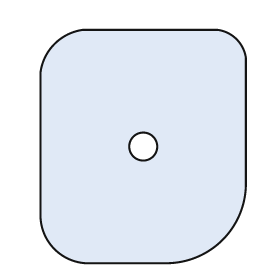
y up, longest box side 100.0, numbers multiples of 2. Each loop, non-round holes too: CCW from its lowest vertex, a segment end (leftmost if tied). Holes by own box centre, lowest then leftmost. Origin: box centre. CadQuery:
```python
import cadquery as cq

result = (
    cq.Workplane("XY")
    .moveTo(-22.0, -50.0)
    .lineTo(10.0, -50.0)
    .threePointArc((34.0, -40.0), (44.0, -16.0))
    .lineTo(44.0, 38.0)
    .threePointArc((40.0, 46.0), (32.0, 50.0))
    .lineTo(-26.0, 50.0)
    .threePointArc((-38.0, 44.0), (-44.0, 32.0))
    .lineTo(-44.0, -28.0)
    .threePointArc((-38.0, -44.0), (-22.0, -50.0))
    .close()
    .moveTo(0.0, 0.0)
    .circle(6.0)
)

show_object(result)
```